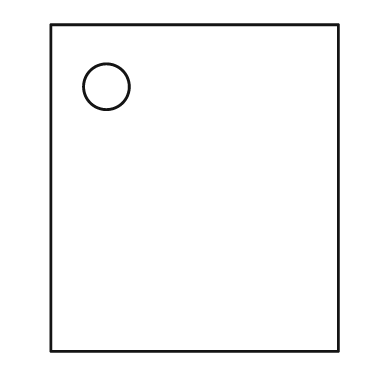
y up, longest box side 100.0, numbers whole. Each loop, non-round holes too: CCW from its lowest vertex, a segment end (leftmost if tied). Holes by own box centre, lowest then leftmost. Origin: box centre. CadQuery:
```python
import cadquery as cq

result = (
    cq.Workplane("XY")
    .moveTo(-44.0, -50.0)
    .lineTo(44.0, -50.0)
    .lineTo(44.0, 50.0)
    .lineTo(-44.0, 50.0)
    .close()
    .moveTo(-27.0, 31.0)
    .circle(7.0)
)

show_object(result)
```